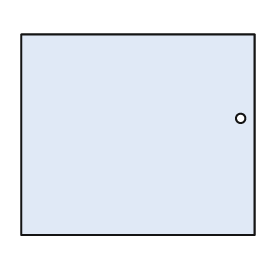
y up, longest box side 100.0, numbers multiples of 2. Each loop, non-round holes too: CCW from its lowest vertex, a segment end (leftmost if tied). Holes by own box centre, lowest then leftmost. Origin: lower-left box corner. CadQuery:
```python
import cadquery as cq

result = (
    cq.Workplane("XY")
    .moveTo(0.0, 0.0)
    .lineTo(100.0, 0.0)
    .lineTo(100.0, 86.0)
    .lineTo(0.0, 86.0)
    .close()
    .moveTo(94.0, 50.0)
    .circle(2.0)
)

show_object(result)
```